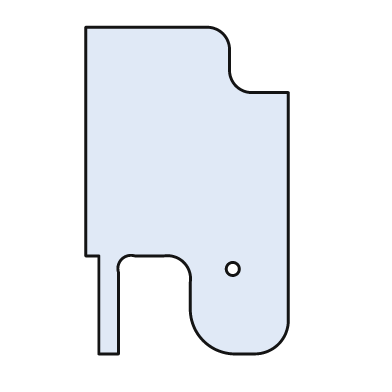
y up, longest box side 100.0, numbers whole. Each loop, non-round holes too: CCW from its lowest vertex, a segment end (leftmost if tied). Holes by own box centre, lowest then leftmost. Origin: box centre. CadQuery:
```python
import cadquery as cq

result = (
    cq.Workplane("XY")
    .moveTo(-27.0, -50.0)
    .lineTo(-21.0, -50.0)
    .lineTo(-21.0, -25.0)
    .threePointArc((-20.0, -21.0), (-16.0, -20.0))
    .lineTo(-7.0, -20.0)
    .threePointArc((-1.0, -22.0), (1.0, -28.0))
    .lineTo(1.0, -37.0)
    .threePointArc((5.0, -46.0), (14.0, -50.0))
    .lineTo(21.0, -50.0)
    .threePointArc((28.0, -47.0), (31.0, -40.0))
    .lineTo(31.0, 30.0)
    .lineTo(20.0, 30.0)
    .threePointArc((15.0, 32.0), (13.0, 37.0))
    .lineTo(13.0, 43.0)
    .threePointArc((11.0, 48.0), (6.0, 50.0))
    .lineTo(-31.0, 50.0)
    .lineTo(-31.0, -20.0)
    .lineTo(-27.0, -20.0)
    .close()
    .moveTo(14.0, -24.0)
    .circle(2.0)
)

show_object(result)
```